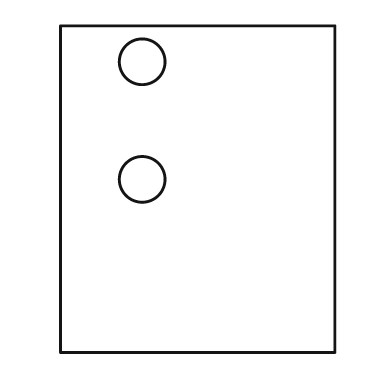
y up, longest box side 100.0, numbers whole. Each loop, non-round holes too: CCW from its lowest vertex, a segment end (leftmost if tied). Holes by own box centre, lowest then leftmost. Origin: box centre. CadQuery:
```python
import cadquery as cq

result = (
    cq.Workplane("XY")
    .moveTo(-42.0, -50.0)
    .lineTo(42.0, -50.0)
    .lineTo(42.0, 50.0)
    .lineTo(-42.0, 50.0)
    .close()
    .moveTo(-17.0, 3.0)
    .circle(7.0)
    .moveTo(-17.0, 39.0)
    .circle(7.0)
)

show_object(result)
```